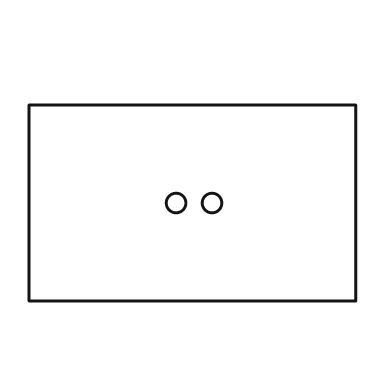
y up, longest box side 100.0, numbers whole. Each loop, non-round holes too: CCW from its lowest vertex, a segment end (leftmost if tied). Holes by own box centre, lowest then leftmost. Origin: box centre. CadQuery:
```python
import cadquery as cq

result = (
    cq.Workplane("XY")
    .moveTo(-50.0, -30.0)
    .lineTo(50.0, -30.0)
    .lineTo(50.0, 30.0)
    .lineTo(-50.0, 30.0)
    .close()
    .moveTo(-5.0, 0.0)
    .circle(3.0)
    .moveTo(6.0, 0.0)
    .circle(3.0)
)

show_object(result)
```